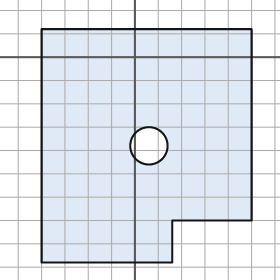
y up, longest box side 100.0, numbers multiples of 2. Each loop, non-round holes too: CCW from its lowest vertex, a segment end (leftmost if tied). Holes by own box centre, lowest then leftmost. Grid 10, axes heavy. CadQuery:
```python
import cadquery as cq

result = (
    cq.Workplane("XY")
    .moveTo(-40.0, -88.0)
    .lineTo(16.0, -88.0)
    .lineTo(16.0, -70.0)
    .lineTo(50.0, -70.0)
    .lineTo(50.0, 12.0)
    .lineTo(-40.0, 12.0)
    .close()
    .moveTo(6.0, -38.0)
    .circle(8.0)
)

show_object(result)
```